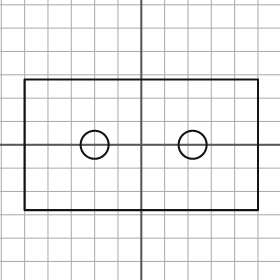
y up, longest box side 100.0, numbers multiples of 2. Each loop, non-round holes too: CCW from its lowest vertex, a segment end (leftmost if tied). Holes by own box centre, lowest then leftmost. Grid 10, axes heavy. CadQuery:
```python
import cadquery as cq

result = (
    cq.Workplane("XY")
    .moveTo(-50.0, -28.0)
    .lineTo(50.0, -28.0)
    .lineTo(50.0, 28.0)
    .lineTo(-50.0, 28.0)
    .close()
    .moveTo(-20.0, 0.0)
    .circle(6.0)
    .moveTo(22.0, 0.0)
    .circle(6.0)
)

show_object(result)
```